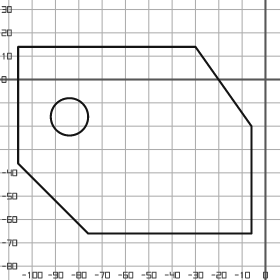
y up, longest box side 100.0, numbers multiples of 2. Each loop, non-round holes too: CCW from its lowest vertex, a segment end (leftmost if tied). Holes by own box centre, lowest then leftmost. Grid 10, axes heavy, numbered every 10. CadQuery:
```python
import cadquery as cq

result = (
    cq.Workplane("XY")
    .moveTo(-76.0, -66.0)
    .lineTo(-6.0, -66.0)
    .lineTo(-6.0, -20.0)
    .lineTo(-30.0, 14.0)
    .lineTo(-106.0, 14.0)
    .lineTo(-106.0, -36.0)
    .close()
    .moveTo(-84.0, -16.0)
    .circle(8.0)
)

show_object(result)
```